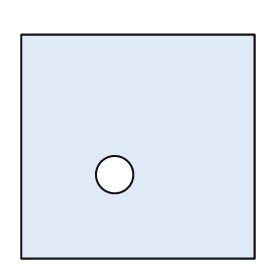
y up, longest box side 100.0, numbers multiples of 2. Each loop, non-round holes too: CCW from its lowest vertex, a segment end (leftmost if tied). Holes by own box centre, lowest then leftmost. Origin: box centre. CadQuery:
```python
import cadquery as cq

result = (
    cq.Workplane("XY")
    .moveTo(-50.0, -48.0)
    .lineTo(50.0, -48.0)
    .lineTo(50.0, 48.0)
    .lineTo(-50.0, 48.0)
    .close()
    .moveTo(-10.0, -12.0)
    .circle(8.0)
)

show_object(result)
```